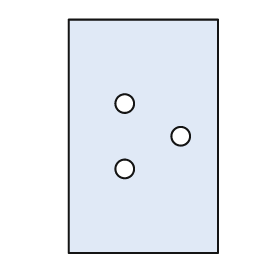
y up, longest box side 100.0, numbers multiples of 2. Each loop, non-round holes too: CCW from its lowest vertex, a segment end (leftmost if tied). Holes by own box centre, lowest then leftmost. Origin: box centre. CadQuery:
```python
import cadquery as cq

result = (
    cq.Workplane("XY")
    .moveTo(-32.0, -50.0)
    .lineTo(32.0, -50.0)
    .lineTo(32.0, 50.0)
    .lineTo(-32.0, 50.0)
    .close()
    .moveTo(-8.0, -14.0)
    .circle(4.0)
    .moveTo(16.0, 0.0)
    .circle(4.0)
    .moveTo(-8.0, 14.0)
    .circle(4.0)
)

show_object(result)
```